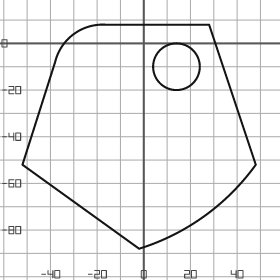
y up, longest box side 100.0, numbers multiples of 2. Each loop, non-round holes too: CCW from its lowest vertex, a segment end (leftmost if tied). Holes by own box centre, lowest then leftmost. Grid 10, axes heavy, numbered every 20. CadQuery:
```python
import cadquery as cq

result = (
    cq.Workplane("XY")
    .moveTo(-2.0, -88.0)
    .threePointArc((26.0, -74.0), (48.0, -52.0))
    .lineTo(28.0, 8.0)
    .lineTo(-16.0, 8.0)
    .threePointArc((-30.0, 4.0), (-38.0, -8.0))
    .lineTo(-52.0, -52.0)
    .close()
    .moveTo(14.0, -10.0)
    .circle(10.0)
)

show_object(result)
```